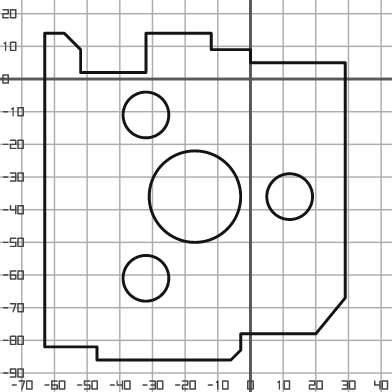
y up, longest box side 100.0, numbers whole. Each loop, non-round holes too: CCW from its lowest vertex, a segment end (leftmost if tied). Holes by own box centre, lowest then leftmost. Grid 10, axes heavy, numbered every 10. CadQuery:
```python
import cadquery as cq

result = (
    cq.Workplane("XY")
    .moveTo(-47.0, -86.0)
    .lineTo(-6.0, -86.0)
    .lineTo(-3.0, -83.0)
    .lineTo(-3.0, -78.0)
    .lineTo(20.0, -78.0)
    .lineTo(29.0, -67.0)
    .lineTo(29.0, 5.0)
    .lineTo(0.0, 5.0)
    .lineTo(0.0, 9.0)
    .lineTo(-12.0, 9.0)
    .lineTo(-12.0, 14.0)
    .lineTo(-32.0, 14.0)
    .lineTo(-32.0, 2.0)
    .lineTo(-52.0, 2.0)
    .lineTo(-52.0, 9.0)
    .lineTo(-57.0, 14.0)
    .lineTo(-63.0, 14.0)
    .lineTo(-63.0, -82.0)
    .lineTo(-47.0, -82.0)
    .close()
    .moveTo(-32.0, -61.0)
    .circle(7.0)
    .moveTo(-17.0, -36.0)
    .circle(14.0)
    .moveTo(12.0, -36.0)
    .circle(7.0)
    .moveTo(-32.0, -11.0)
    .circle(7.0)
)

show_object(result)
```